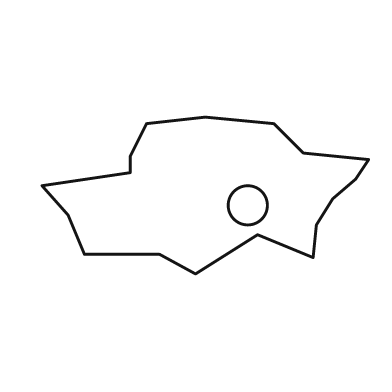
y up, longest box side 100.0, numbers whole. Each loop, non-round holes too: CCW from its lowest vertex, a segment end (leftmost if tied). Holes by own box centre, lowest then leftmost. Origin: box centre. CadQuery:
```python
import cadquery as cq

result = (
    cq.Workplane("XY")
    .moveTo(-3.0, -24.0)
    .lineTo(16.0, -12.0)
    .lineTo(33.0, -19.0)
    .lineTo(34.0, -9.0)
    .lineTo(39.0, -1.0)
    .lineTo(46.0, 5.0)
    .lineTo(50.0, 11.0)
    .lineTo(30.0, 13.0)
    .lineTo(21.0, 22.0)
    .lineTo(0.0, 24.0)
    .lineTo(-18.0, 22.0)
    .lineTo(-23.0, 12.0)
    .lineTo(-23.0, 7.0)
    .lineTo(-50.0, 3.0)
    .lineTo(-42.0, -6.0)
    .lineTo(-37.0, -18.0)
    .lineTo(-14.0, -18.0)
    .close()
    .moveTo(13.0, -3.0)
    .circle(6.0)
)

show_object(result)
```